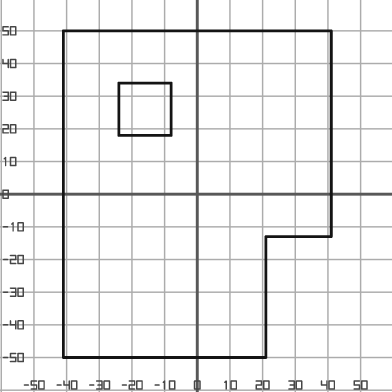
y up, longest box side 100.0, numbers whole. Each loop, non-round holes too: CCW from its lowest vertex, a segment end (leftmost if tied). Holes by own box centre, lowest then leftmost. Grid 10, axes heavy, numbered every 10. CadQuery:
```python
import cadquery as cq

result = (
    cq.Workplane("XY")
    .moveTo(-41.0, -50.0)
    .lineTo(21.0, -50.0)
    .lineTo(21.0, -13.0)
    .lineTo(41.0, -13.0)
    .lineTo(41.0, 50.0)
    .lineTo(-41.0, 50.0)
    .close()
    .moveTo(-24.0, 18.0)
    .lineTo(-8.0, 18.0)
    .lineTo(-8.0, 34.0)
    .lineTo(-24.0, 34.0)
    .close()
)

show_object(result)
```